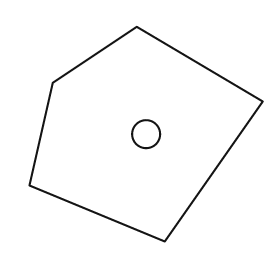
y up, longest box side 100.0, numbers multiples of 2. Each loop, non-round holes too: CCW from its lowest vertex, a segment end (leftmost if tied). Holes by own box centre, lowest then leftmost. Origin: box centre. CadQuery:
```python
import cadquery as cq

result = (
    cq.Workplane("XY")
    .moveTo(8.0, -46.0)
    .lineTo(50.0, 14.0)
    .lineTo(-4.0, 46.0)
    .lineTo(-40.0, 22.0)
    .lineTo(-50.0, -22.0)
    .close()
    .moveTo(0.0, 0.0)
    .circle(6.0)
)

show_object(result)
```